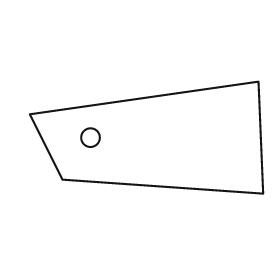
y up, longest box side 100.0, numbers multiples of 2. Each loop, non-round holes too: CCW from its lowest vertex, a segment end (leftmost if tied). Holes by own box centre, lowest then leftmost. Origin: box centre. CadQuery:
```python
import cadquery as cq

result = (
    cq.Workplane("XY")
    .moveTo(50.0, -24.0)
    .lineTo(48.0, 24.0)
    .lineTo(-50.0, 10.0)
    .lineTo(-36.0, -18.0)
    .close()
    .moveTo(-24.0, 0.0)
    .circle(4.0)
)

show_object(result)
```